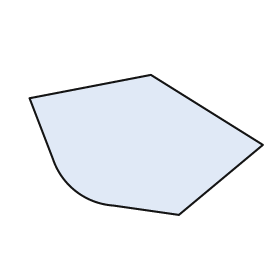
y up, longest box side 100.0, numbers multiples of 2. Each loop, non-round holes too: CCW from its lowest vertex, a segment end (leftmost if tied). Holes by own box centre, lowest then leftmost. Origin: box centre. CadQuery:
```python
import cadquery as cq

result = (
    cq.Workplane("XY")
    .moveTo(14.0, -30.0)
    .lineTo(50.0, 0.0)
    .lineTo(2.0, 30.0)
    .lineTo(-50.0, 20.0)
    .lineTo(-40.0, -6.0)
    .threePointArc((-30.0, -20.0), (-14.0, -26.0))
    .close()
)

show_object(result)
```